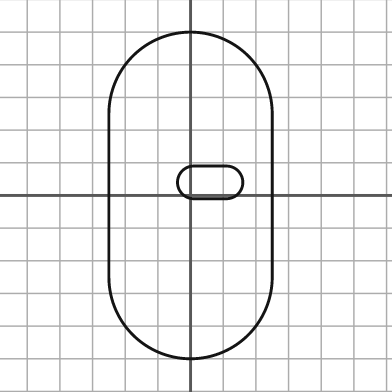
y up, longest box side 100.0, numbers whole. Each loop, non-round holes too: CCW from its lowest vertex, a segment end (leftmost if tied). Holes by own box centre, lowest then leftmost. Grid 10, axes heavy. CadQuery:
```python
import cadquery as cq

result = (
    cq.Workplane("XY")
    .moveTo(-25.0, -25.0)
    .threePointArc((0.0, -50.0), (25.0, -25.0))
    .lineTo(25.0, 25.0)
    .threePointArc((0.0, 50.0), (-25.0, 25.0))
    .close()
    .moveTo(1.0, -1.0)
    .lineTo(11.0, -1.0)
    .threePointArc((16.0, 4.0), (11.0, 9.0))
    .lineTo(1.0, 9.0)
    .threePointArc((-4.0, 4.0), (1.0, -1.0))
    .close()
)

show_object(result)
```